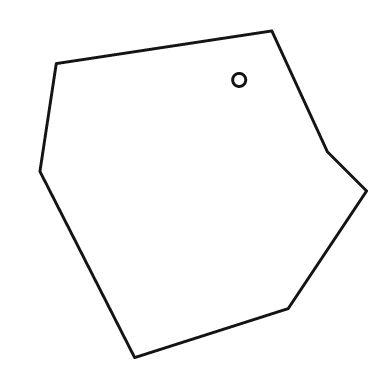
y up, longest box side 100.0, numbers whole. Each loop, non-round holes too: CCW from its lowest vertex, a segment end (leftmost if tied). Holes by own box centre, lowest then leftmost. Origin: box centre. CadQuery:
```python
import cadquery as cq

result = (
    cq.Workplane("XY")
    .moveTo(-21.0, -50.0)
    .lineTo(26.0, -35.0)
    .lineTo(50.0, 1.0)
    .lineTo(38.0, 13.0)
    .lineTo(21.0, 50.0)
    .lineTo(-45.0, 40.0)
    .lineTo(-50.0, 7.0)
    .close()
    .moveTo(11.0, 35.0)
    .circle(2.0)
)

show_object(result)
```